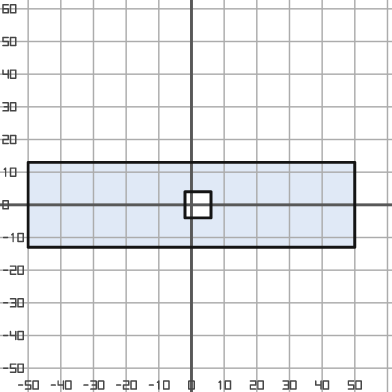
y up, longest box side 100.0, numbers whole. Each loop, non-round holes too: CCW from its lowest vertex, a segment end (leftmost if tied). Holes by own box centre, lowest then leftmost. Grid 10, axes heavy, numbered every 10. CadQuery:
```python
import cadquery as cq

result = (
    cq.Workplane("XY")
    .moveTo(-50.0, -13.0)
    .lineTo(50.0, -13.0)
    .lineTo(50.0, 13.0)
    .lineTo(-50.0, 13.0)
    .close()
    .moveTo(-2.0, -4.0)
    .lineTo(6.0, -4.0)
    .lineTo(6.0, 4.0)
    .lineTo(-2.0, 4.0)
    .close()
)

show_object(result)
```